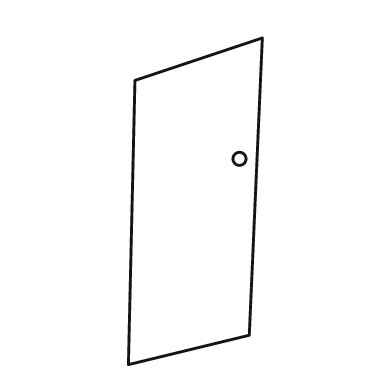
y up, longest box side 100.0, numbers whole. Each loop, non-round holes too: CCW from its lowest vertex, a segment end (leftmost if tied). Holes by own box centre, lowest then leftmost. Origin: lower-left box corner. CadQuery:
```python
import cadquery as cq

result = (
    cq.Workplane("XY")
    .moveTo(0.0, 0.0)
    .lineTo(37.0, 9.0)
    .lineTo(41.0, 100.0)
    .lineTo(2.0, 87.0)
    .close()
    .moveTo(34.0, 63.0)
    .circle(2.0)
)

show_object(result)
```